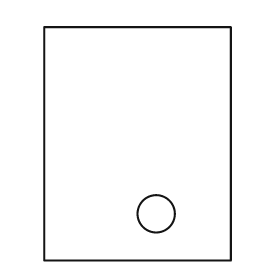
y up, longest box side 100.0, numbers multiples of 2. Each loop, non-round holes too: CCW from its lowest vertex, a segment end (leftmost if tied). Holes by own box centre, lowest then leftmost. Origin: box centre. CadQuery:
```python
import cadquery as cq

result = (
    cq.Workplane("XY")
    .moveTo(-40.0, -50.0)
    .lineTo(40.0, -50.0)
    .lineTo(40.0, 50.0)
    .lineTo(-40.0, 50.0)
    .close()
    .moveTo(8.0, -30.0)
    .circle(8.0)
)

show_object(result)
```